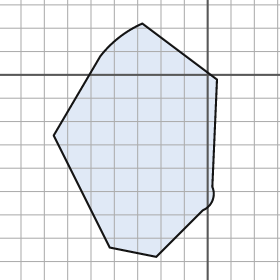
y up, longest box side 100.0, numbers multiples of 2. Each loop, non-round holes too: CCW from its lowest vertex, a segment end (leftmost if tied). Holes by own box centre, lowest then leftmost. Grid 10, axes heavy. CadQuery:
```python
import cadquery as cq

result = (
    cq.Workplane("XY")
    .moveTo(-22.0, -78.0)
    .lineTo(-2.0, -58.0)
    .threePointArc((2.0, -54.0), (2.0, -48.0))
    .lineTo(4.0, -2.0)
    .lineTo(-28.0, 22.0)
    .threePointArc((-38.0, 16.0), (-46.0, 8.0))
    .lineTo(-66.0, -26.0)
    .lineTo(-42.0, -74.0)
    .close()
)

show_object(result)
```